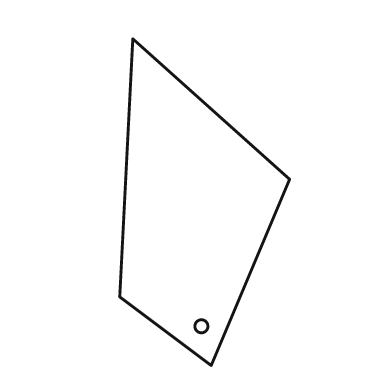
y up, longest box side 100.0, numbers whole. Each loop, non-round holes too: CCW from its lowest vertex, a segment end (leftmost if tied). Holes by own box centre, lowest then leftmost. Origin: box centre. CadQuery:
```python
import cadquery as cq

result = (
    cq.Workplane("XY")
    .moveTo(2.0, -50.0)
    .lineTo(26.0, 7.0)
    .lineTo(-22.0, 50.0)
    .lineTo(-26.0, -29.0)
    .close()
    .moveTo(-1.0, -38.0)
    .circle(2.0)
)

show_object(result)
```